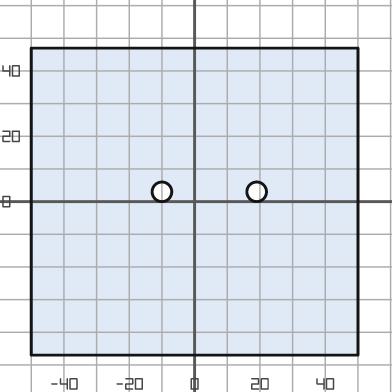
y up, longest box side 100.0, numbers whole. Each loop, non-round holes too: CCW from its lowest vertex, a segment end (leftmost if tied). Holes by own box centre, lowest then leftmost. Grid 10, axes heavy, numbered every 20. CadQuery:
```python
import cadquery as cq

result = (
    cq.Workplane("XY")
    .moveTo(-50.0, -47.0)
    .lineTo(50.0, -47.0)
    .lineTo(50.0, 47.0)
    .lineTo(-50.0, 47.0)
    .close()
    .moveTo(-10.0, 3.0)
    .circle(3.0)
    .moveTo(19.0, 3.0)
    .circle(3.0)
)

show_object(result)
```